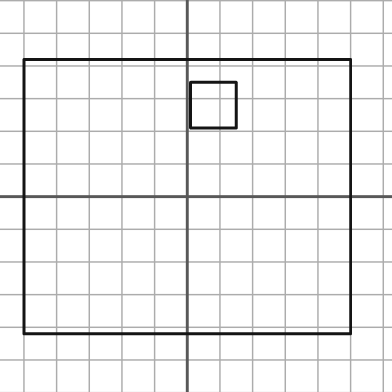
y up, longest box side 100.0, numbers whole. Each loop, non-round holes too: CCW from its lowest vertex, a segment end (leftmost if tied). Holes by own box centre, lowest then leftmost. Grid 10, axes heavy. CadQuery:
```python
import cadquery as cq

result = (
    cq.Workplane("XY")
    .moveTo(-50.0, -42.0)
    .lineTo(50.0, -42.0)
    .lineTo(50.0, 42.0)
    .lineTo(-50.0, 42.0)
    .close()
    .moveTo(1.0, 21.0)
    .lineTo(15.0, 21.0)
    .lineTo(15.0, 35.0)
    .lineTo(1.0, 35.0)
    .close()
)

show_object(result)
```